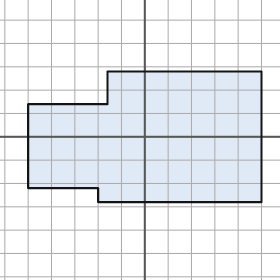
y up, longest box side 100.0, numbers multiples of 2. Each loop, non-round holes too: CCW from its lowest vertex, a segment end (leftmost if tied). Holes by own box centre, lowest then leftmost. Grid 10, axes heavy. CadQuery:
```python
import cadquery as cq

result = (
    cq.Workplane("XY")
    .moveTo(-20.0, -28.0)
    .lineTo(50.0, -28.0)
    .lineTo(50.0, 28.0)
    .lineTo(-16.0, 28.0)
    .lineTo(-16.0, 14.0)
    .lineTo(-50.0, 14.0)
    .lineTo(-50.0, -22.0)
    .lineTo(-20.0, -22.0)
    .close()
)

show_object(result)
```